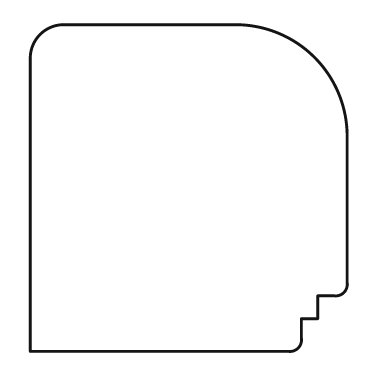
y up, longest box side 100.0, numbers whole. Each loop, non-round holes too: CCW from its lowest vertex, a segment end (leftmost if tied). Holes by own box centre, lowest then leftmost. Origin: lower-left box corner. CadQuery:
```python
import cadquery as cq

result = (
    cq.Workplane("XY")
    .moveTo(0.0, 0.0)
    .lineTo(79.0, 0.0)
    .threePointArc((82.0, 1.0), (83.0, 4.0))
    .lineTo(83.0, 10.0)
    .lineTo(88.0, 10.0)
    .lineTo(88.0, 17.0)
    .lineTo(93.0, 17.0)
    .threePointArc((96.0, 18.0), (97.0, 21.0))
    .lineTo(97.0, 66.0)
    .threePointArc((87.0, 90.0), (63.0, 100.0))
    .lineTo(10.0, 100.0)
    .threePointArc((3.0, 97.0), (0.0, 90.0))
    .close()
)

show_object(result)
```